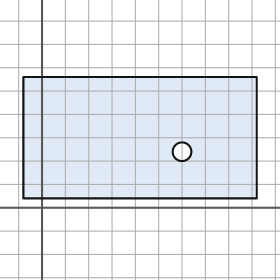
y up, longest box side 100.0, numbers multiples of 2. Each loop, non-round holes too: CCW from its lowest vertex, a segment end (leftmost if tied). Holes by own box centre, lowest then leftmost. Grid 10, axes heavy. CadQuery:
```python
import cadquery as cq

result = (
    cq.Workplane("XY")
    .moveTo(-8.0, 4.0)
    .lineTo(92.0, 4.0)
    .lineTo(92.0, 56.0)
    .lineTo(-8.0, 56.0)
    .close()
    .moveTo(60.0, 24.0)
    .circle(4.0)
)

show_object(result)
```